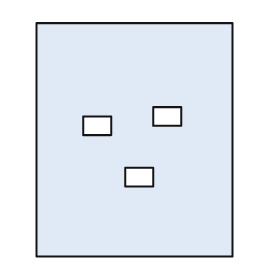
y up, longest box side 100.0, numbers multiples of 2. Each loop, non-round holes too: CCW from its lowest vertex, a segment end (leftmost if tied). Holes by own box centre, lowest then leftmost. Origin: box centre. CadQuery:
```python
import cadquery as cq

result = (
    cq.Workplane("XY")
    .moveTo(-42.0, -50.0)
    .lineTo(42.0, -50.0)
    .lineTo(42.0, 50.0)
    .lineTo(-42.0, 50.0)
    .close()
    .moveTo(-4.0, -20.0)
    .lineTo(8.0, -20.0)
    .lineTo(8.0, -12.0)
    .lineTo(-4.0, -12.0)
    .close()
    .moveTo(-22.0, 2.0)
    .lineTo(-10.0, 2.0)
    .lineTo(-10.0, 10.0)
    .lineTo(-22.0, 10.0)
    .close()
    .moveTo(8.0, 6.0)
    .lineTo(20.0, 6.0)
    .lineTo(20.0, 14.0)
    .lineTo(8.0, 14.0)
    .close()
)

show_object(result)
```